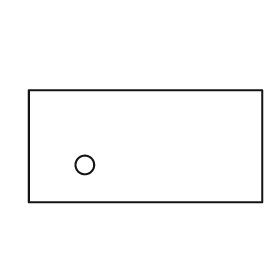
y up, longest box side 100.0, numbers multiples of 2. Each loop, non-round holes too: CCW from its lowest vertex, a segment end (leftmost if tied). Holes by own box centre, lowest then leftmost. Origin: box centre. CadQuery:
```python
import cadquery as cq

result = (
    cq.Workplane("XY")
    .moveTo(-50.0, -24.0)
    .lineTo(50.0, -24.0)
    .lineTo(50.0, 24.0)
    .lineTo(-50.0, 24.0)
    .close()
    .moveTo(-26.0, -8.0)
    .circle(4.0)
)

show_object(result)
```